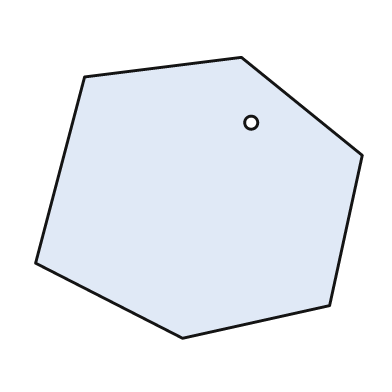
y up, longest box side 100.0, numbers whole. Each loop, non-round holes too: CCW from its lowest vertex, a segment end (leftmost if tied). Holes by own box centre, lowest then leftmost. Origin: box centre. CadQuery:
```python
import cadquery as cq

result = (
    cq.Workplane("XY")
    .moveTo(-5.0, -43.0)
    .lineTo(40.0, -33.0)
    .lineTo(50.0, 13.0)
    .lineTo(13.0, 43.0)
    .lineTo(-35.0, 37.0)
    .lineTo(-50.0, -20.0)
    .close()
    .moveTo(16.0, 23.0)
    .circle(2.0)
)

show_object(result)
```